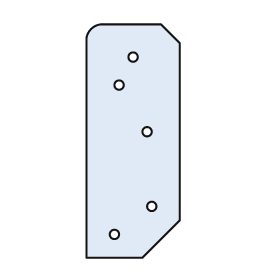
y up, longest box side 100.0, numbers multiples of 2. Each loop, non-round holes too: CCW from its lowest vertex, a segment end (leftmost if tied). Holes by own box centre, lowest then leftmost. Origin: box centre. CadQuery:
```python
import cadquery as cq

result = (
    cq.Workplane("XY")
    .moveTo(-20.0, -50.0)
    .lineTo(4.0, -50.0)
    .lineTo(20.0, -34.0)
    .lineTo(20.0, 42.0)
    .lineTo(12.0, 50.0)
    .lineTo(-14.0, 50.0)
    .threePointArc((-18.0, 48.0), (-20.0, 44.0))
    .close()
    .moveTo(-8.0, -40.0)
    .circle(2.0)
    .moveTo(8.0, -28.0)
    .circle(2.0)
    .moveTo(6.0, 4.0)
    .circle(2.0)
    .moveTo(-6.0, 24.0)
    .circle(2.0)
    .moveTo(0.0, 36.0)
    .circle(2.0)
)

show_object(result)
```